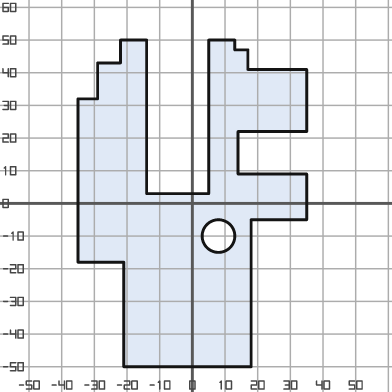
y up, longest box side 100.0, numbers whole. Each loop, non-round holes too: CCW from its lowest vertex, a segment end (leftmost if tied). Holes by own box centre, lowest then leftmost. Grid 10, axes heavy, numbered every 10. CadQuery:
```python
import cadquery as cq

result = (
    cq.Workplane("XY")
    .moveTo(-21.0, -50.0)
    .lineTo(18.0, -50.0)
    .lineTo(18.0, -5.0)
    .lineTo(35.0, -5.0)
    .lineTo(35.0, 9.0)
    .lineTo(14.0, 9.0)
    .lineTo(14.0, 22.0)
    .lineTo(35.0, 22.0)
    .lineTo(35.0, 41.0)
    .lineTo(17.0, 41.0)
    .lineTo(17.0, 47.0)
    .lineTo(13.0, 47.0)
    .lineTo(13.0, 50.0)
    .lineTo(5.0, 50.0)
    .lineTo(5.0, 3.0)
    .lineTo(-14.0, 3.0)
    .lineTo(-14.0, 50.0)
    .lineTo(-22.0, 50.0)
    .lineTo(-22.0, 43.0)
    .lineTo(-29.0, 43.0)
    .lineTo(-29.0, 32.0)
    .lineTo(-35.0, 32.0)
    .lineTo(-35.0, -18.0)
    .lineTo(-21.0, -18.0)
    .close()
    .moveTo(8.0, -10.0)
    .circle(5.0)
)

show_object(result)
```